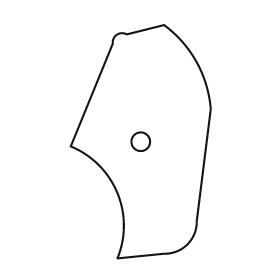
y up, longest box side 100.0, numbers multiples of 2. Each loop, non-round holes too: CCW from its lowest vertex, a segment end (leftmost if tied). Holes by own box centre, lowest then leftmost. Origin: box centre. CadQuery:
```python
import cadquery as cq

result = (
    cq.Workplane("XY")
    .moveTo(-10.0, -50.0)
    .lineTo(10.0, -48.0)
    .threePointArc((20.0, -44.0), (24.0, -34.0))
    .lineTo(30.0, 14.0)
    .threePointArc((24.0, 34.0), (10.0, 50.0))
    .lineTo(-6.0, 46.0)
    .threePointArc((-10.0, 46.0), (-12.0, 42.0))
    .lineTo(-30.0, -2.0)
    .threePointArc((-10.0, -22.0), (-10.0, -50.0))
    .close()
    .moveTo(0.0, 0.0)
    .circle(4.0)
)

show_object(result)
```